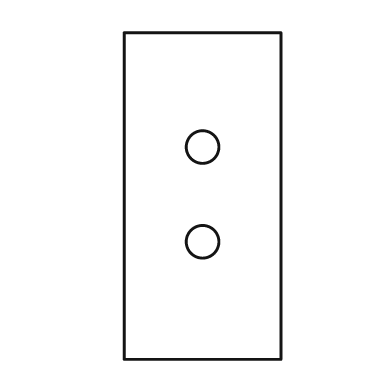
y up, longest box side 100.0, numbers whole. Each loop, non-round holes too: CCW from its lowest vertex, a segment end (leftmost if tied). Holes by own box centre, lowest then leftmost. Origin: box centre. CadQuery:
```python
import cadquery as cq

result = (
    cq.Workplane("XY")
    .moveTo(-24.0, -50.0)
    .lineTo(24.0, -50.0)
    .lineTo(24.0, 50.0)
    .lineTo(-24.0, 50.0)
    .close()
    .moveTo(0.0, -14.0)
    .circle(5.0)
    .moveTo(0.0, 15.0)
    .circle(5.0)
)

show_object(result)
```